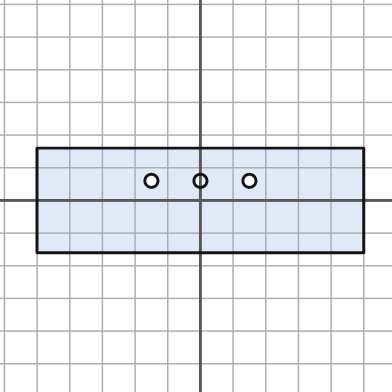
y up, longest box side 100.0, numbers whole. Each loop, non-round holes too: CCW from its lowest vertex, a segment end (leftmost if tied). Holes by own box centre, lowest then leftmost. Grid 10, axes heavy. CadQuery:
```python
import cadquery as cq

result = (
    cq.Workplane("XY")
    .moveTo(-50.0, -16.0)
    .lineTo(50.0, -16.0)
    .lineTo(50.0, 16.0)
    .lineTo(-50.0, 16.0)
    .close()
    .moveTo(-15.0, 6.0)
    .circle(2.0)
    .moveTo(0.0, 6.0)
    .circle(2.0)
    .moveTo(15.0, 6.0)
    .circle(2.0)
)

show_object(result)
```